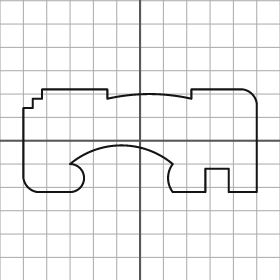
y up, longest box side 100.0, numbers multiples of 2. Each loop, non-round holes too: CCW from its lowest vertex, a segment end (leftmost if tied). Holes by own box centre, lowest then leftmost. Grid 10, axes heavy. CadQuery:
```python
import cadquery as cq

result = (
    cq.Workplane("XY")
    .moveTo(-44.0, -22.0)
    .lineTo(-30.0, -22.0)
    .threePointArc((-24.0, -16.0), (-30.0, -10.0))
    .threePointArc((-8.0, -2.0), (14.0, -10.0))
    .threePointArc((12.0, -16.0), (14.0, -22.0))
    .lineTo(28.0, -22.0)
    .lineTo(28.0, -12.0)
    .lineTo(38.0, -12.0)
    .lineTo(38.0, -22.0)
    .lineTo(50.0, -22.0)
    .lineTo(50.0, 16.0)
    .threePointArc((48.0, 20.0), (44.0, 22.0))
    .lineTo(22.0, 22.0)
    .lineTo(22.0, 18.0)
    .threePointArc((4.0, 20.0), (-14.0, 18.0))
    .lineTo(-14.0, 22.0)
    .lineTo(-42.0, 22.0)
    .lineTo(-42.0, 18.0)
    .lineTo(-46.0, 18.0)
    .lineTo(-46.0, 14.0)
    .lineTo(-50.0, 14.0)
    .lineTo(-50.0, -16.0)
    .threePointArc((-48.0, -20.0), (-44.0, -22.0))
    .close()
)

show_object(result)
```